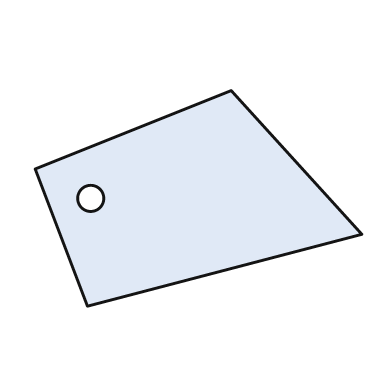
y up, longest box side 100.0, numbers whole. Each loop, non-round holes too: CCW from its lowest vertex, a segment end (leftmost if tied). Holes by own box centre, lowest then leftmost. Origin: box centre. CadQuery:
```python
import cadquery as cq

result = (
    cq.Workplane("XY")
    .moveTo(-34.0, -33.0)
    .lineTo(50.0, -11.0)
    .lineTo(10.0, 33.0)
    .lineTo(-50.0, 9.0)
    .close()
    .moveTo(-33.0, 0.0)
    .circle(4.0)
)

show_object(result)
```